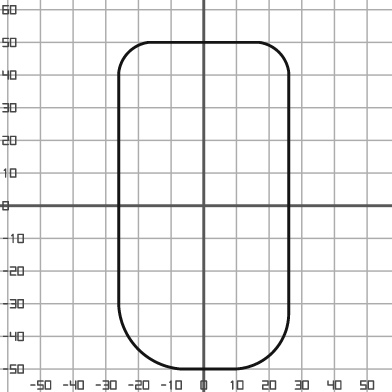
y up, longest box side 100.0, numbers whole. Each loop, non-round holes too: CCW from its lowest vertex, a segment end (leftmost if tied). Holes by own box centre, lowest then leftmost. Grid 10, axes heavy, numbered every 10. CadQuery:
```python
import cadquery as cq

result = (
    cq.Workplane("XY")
    .moveTo(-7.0, -50.0)
    .lineTo(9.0, -50.0)
    .threePointArc((21.0, -45.0), (26.0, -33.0))
    .lineTo(26.0, 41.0)
    .threePointArc((23.0, 47.0), (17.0, 50.0))
    .lineTo(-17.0, 50.0)
    .threePointArc((-23.0, 47.0), (-26.0, 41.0))
    .lineTo(-26.0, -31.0)
    .threePointArc((-20.0, -44.0), (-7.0, -50.0))
    .close()
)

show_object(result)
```